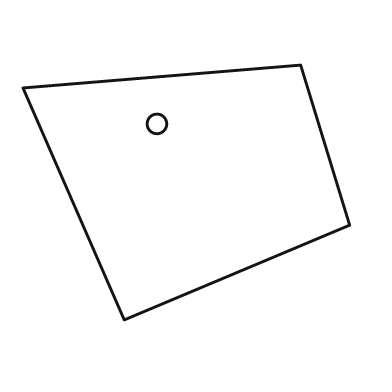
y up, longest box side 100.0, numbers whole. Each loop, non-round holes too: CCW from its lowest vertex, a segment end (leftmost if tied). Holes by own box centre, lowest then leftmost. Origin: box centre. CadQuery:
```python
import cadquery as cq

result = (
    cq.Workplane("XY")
    .moveTo(-19.0, -39.0)
    .lineTo(50.0, -10.0)
    .lineTo(35.0, 39.0)
    .lineTo(-50.0, 32.0)
    .close()
    .moveTo(-9.0, 21.0)
    .circle(3.0)
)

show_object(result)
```